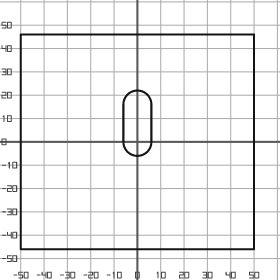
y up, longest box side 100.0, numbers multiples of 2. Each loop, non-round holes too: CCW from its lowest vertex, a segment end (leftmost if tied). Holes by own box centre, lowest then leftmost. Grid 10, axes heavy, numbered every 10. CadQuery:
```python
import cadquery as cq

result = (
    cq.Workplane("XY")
    .moveTo(-50.0, -46.0)
    .lineTo(50.0, -46.0)
    .lineTo(50.0, 46.0)
    .lineTo(-50.0, 46.0)
    .close()
    .moveTo(-6.0, 0.0)
    .threePointArc((0.0, -6.0), (6.0, 0.0))
    .lineTo(6.0, 16.0)
    .threePointArc((0.0, 22.0), (-6.0, 16.0))
    .close()
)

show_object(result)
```